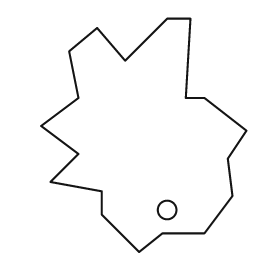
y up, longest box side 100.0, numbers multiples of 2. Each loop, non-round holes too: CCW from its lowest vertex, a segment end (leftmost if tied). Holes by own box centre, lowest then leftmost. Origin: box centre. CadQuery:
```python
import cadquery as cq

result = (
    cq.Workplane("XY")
    .moveTo(-2.0, -50.0)
    .lineTo(8.0, -42.0)
    .lineTo(26.0, -42.0)
    .lineTo(38.0, -26.0)
    .lineTo(36.0, -10.0)
    .lineTo(44.0, 2.0)
    .lineTo(26.0, 16.0)
    .lineTo(18.0, 16.0)
    .lineTo(20.0, 50.0)
    .lineTo(10.0, 50.0)
    .lineTo(-8.0, 32.0)
    .lineTo(-20.0, 46.0)
    .lineTo(-32.0, 36.0)
    .lineTo(-28.0, 16.0)
    .lineTo(-44.0, 4.0)
    .lineTo(-28.0, -8.0)
    .lineTo(-40.0, -20.0)
    .lineTo(-18.0, -24.0)
    .lineTo(-18.0, -34.0)
    .close()
    .moveTo(10.0, -32.0)
    .circle(4.0)
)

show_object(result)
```